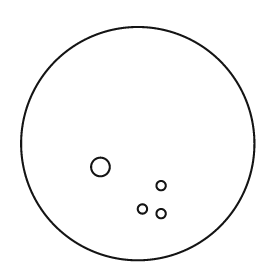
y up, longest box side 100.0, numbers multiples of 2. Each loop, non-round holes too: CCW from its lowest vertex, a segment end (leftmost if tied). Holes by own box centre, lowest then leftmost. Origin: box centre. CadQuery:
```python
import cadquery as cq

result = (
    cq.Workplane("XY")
    .moveTo(0.0, 0.0)
    .circle(50.0)
    .moveTo(10.0, -30.0)
    .circle(2.0)
    .moveTo(2.0, -28.0)
    .circle(2.0)
    .moveTo(10.0, -18.0)
    .circle(2.0)
    .moveTo(-16.0, -10.0)
    .circle(4.0)
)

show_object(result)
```